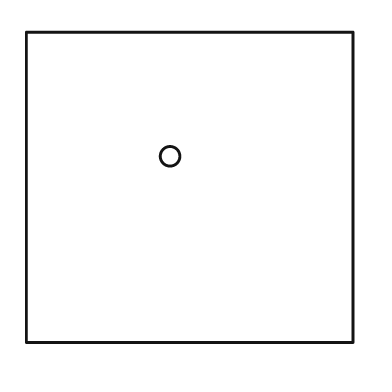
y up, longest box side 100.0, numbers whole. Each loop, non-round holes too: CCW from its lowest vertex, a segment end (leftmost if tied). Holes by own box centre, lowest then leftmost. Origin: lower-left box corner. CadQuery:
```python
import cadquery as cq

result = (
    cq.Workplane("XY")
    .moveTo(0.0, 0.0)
    .lineTo(100.0, 0.0)
    .lineTo(100.0, 95.0)
    .lineTo(0.0, 95.0)
    .close()
    .moveTo(44.0, 57.0)
    .circle(3.0)
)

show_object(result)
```